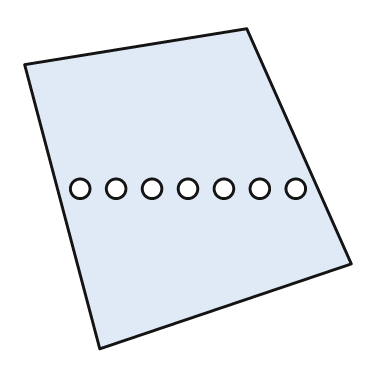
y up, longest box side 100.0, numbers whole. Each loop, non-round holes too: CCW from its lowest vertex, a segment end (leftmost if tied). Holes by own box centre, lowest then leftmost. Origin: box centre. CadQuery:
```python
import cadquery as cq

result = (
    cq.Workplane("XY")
    .moveTo(-27.0, -49.0)
    .lineTo(50.0, -23.0)
    .lineTo(18.0, 49.0)
    .lineTo(-50.0, 38.0)
    .close()
    .moveTo(-33.0, 0.0)
    .circle(3.0)
    .moveTo(-22.0, 0.0)
    .circle(3.0)
    .moveTo(-11.0, 0.0)
    .circle(3.0)
    .moveTo(0.0, 0.0)
    .circle(3.0)
    .moveTo(11.0, 0.0)
    .circle(3.0)
    .moveTo(22.0, 0.0)
    .circle(3.0)
    .moveTo(33.0, 0.0)
    .circle(3.0)
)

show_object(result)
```